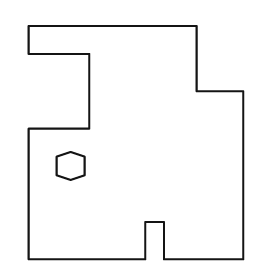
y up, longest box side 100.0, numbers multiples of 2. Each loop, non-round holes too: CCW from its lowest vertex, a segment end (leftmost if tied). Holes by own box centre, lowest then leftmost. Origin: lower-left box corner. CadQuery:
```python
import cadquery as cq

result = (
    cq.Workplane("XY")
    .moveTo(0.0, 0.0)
    .lineTo(50.0, 0.0)
    .lineTo(50.0, 16.0)
    .lineTo(58.0, 16.0)
    .lineTo(58.0, 0.0)
    .lineTo(92.0, 0.0)
    .lineTo(92.0, 72.0)
    .lineTo(72.0, 72.0)
    .lineTo(72.0, 100.0)
    .lineTo(0.0, 100.0)
    .lineTo(0.0, 88.0)
    .lineTo(26.0, 88.0)
    .lineTo(26.0, 56.0)
    .lineTo(0.0, 56.0)
    .close()
    .moveTo(18.0, 34.0)
    .lineTo(24.0, 36.0)
    .lineTo(24.0, 44.0)
    .lineTo(18.0, 46.0)
    .lineTo(12.0, 44.0)
    .lineTo(12.0, 36.0)
    .close()
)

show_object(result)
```